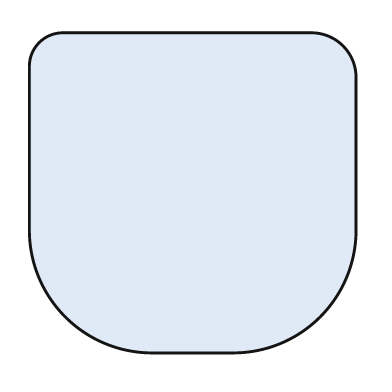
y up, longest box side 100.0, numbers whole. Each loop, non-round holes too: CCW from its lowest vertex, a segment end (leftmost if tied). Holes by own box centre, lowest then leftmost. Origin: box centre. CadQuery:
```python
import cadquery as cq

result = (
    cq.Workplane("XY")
    .moveTo(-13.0, -49.0)
    .lineTo(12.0, -49.0)
    .threePointArc((39.0, -38.0), (50.0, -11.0))
    .lineTo(50.0, 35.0)
    .threePointArc((46.0, 45.0), (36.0, 49.0))
    .lineTo(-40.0, 49.0)
    .threePointArc((-47.0, 46.0), (-50.0, 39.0))
    .lineTo(-50.0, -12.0)
    .threePointArc((-39.0, -38.0), (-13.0, -49.0))
    .close()
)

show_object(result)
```